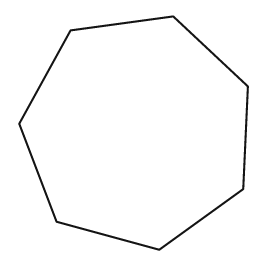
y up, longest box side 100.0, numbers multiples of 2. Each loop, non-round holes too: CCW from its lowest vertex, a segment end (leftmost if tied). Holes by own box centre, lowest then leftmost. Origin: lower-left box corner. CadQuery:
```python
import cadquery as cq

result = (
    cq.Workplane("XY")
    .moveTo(60.0, 0.0)
    .lineTo(96.0, 26.0)
    .lineTo(98.0, 70.0)
    .lineTo(66.0, 100.0)
    .lineTo(22.0, 94.0)
    .lineTo(0.0, 54.0)
    .lineTo(16.0, 12.0)
    .close()
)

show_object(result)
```